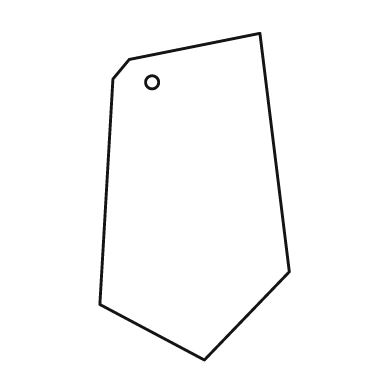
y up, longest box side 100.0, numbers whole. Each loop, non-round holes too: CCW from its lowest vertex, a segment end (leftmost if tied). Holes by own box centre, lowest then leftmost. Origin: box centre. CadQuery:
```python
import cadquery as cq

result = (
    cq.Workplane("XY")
    .moveTo(3.0, -50.0)
    .lineTo(29.0, -23.0)
    .lineTo(20.0, 50.0)
    .lineTo(-20.0, 42.0)
    .lineTo(-25.0, 36.0)
    .lineTo(-29.0, -33.0)
    .close()
    .moveTo(-13.0, 35.0)
    .circle(2.0)
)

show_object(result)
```